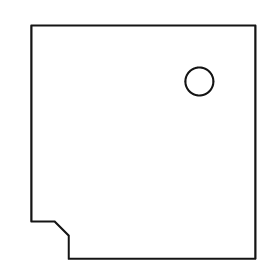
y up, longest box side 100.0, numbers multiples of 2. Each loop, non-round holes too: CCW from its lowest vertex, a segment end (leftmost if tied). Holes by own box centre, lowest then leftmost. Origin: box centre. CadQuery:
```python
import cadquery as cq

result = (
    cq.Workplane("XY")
    .moveTo(-32.0, -50.0)
    .lineTo(48.0, -50.0)
    .lineTo(48.0, 50.0)
    .lineTo(-48.0, 50.0)
    .lineTo(-48.0, -34.0)
    .lineTo(-38.0, -34.0)
    .lineTo(-32.0, -40.0)
    .close()
    .moveTo(24.0, 26.0)
    .circle(6.0)
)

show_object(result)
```